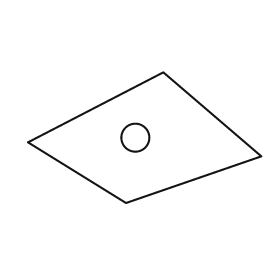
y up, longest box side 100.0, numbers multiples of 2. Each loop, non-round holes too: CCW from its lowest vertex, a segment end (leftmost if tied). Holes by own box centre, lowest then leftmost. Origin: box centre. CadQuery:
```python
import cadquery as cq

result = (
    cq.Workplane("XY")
    .moveTo(-8.0, -28.0)
    .lineTo(50.0, -8.0)
    .lineTo(8.0, 28.0)
    .lineTo(-50.0, -2.0)
    .close()
    .moveTo(-4.0, 0.0)
    .circle(6.0)
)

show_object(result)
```